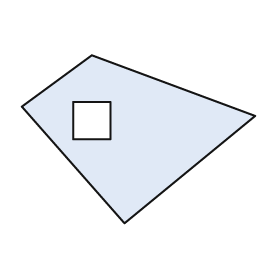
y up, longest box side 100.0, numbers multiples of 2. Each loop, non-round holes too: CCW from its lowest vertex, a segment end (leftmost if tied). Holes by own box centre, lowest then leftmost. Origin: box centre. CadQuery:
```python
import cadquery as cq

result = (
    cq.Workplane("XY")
    .moveTo(-6.0, -36.0)
    .lineTo(50.0, 10.0)
    .lineTo(-20.0, 36.0)
    .lineTo(-50.0, 14.0)
    .close()
    .moveTo(-28.0, 0.0)
    .lineTo(-12.0, 0.0)
    .lineTo(-12.0, 16.0)
    .lineTo(-28.0, 16.0)
    .close()
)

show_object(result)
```